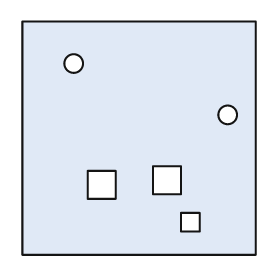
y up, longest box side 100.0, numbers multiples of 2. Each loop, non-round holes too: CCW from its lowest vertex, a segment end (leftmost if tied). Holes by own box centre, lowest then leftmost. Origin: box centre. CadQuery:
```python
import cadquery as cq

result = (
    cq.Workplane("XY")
    .moveTo(-50.0, -50.0)
    .lineTo(50.0, -50.0)
    .lineTo(50.0, 50.0)
    .lineTo(-50.0, 50.0)
    .close()
    .moveTo(18.0, -40.0)
    .lineTo(26.0, -40.0)
    .lineTo(26.0, -32.0)
    .lineTo(18.0, -32.0)
    .close()
    .moveTo(-22.0, -26.0)
    .lineTo(-10.0, -26.0)
    .lineTo(-10.0, -14.0)
    .lineTo(-22.0, -14.0)
    .close()
    .moveTo(6.0, -24.0)
    .lineTo(18.0, -24.0)
    .lineTo(18.0, -12.0)
    .lineTo(6.0, -12.0)
    .close()
    .moveTo(38.0, 10.0)
    .circle(4.0)
    .moveTo(-28.0, 32.0)
    .circle(4.0)
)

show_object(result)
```